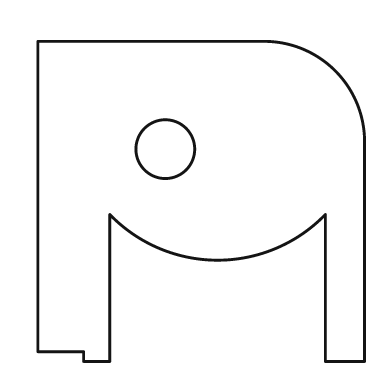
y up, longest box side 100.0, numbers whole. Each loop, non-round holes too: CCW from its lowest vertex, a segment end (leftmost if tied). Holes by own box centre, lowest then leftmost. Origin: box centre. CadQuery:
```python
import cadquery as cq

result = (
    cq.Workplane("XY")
    .moveTo(-36.0, -49.0)
    .lineTo(-28.0, -49.0)
    .lineTo(-28.0, -4.0)
    .threePointArc((5.0, -18.0), (38.0, -4.0))
    .lineTo(38.0, -49.0)
    .lineTo(50.0, -49.0)
    .lineTo(50.0, 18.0)
    .threePointArc((41.0, 40.0), (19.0, 49.0))
    .lineTo(-50.0, 49.0)
    .lineTo(-50.0, -46.0)
    .lineTo(-36.0, -46.0)
    .close()
    .moveTo(-11.0, 16.0)
    .circle(9.0)
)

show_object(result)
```